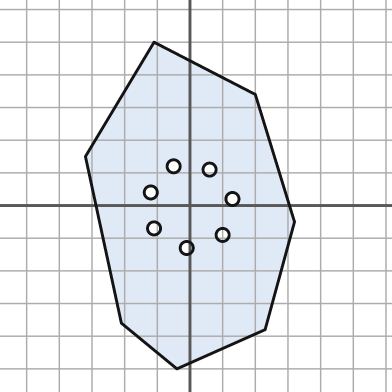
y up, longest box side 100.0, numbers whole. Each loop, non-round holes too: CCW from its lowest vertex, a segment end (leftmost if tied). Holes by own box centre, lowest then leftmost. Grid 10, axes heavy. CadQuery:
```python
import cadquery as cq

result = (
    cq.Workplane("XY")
    .moveTo(-4.0, -50.0)
    .lineTo(23.0, -38.0)
    .lineTo(32.0, -5.0)
    .lineTo(20.0, 34.0)
    .lineTo(-11.0, 50.0)
    .lineTo(-32.0, 15.0)
    .lineTo(-21.0, -36.0)
    .close()
    .moveTo(-1.0, -13.0)
    .circle(2.0)
    .moveTo(10.0, -9.0)
    .circle(2.0)
    .moveTo(-11.0, -7.0)
    .circle(2.0)
    .moveTo(13.0, 2.0)
    .circle(2.0)
    .moveTo(-12.0, 4.0)
    .circle(2.0)
    .moveTo(6.0, 11.0)
    .circle(2.0)
    .moveTo(-5.0, 12.0)
    .circle(2.0)
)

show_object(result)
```